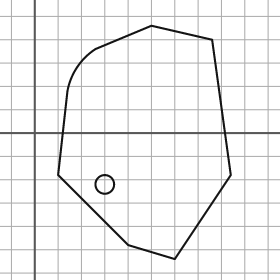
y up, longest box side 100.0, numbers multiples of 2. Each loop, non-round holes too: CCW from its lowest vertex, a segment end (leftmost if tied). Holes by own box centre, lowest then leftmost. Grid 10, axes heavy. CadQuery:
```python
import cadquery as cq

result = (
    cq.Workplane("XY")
    .moveTo(60.0, -54.0)
    .lineTo(84.0, -18.0)
    .lineTo(76.0, 40.0)
    .lineTo(50.0, 46.0)
    .lineTo(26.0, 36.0)
    .threePointArc((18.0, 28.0), (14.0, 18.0))
    .lineTo(10.0, -18.0)
    .lineTo(40.0, -48.0)
    .close()
    .moveTo(30.0, -22.0)
    .circle(4.0)
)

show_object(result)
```